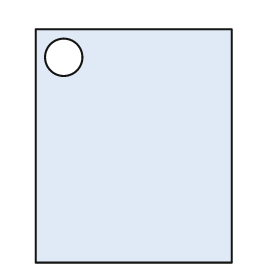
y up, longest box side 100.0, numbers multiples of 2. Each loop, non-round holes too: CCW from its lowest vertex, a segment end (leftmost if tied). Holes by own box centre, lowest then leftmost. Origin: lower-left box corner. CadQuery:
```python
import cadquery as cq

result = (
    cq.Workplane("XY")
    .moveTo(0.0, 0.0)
    .lineTo(84.0, 0.0)
    .lineTo(84.0, 100.0)
    .lineTo(0.0, 100.0)
    .close()
    .moveTo(12.0, 88.0)
    .circle(8.0)
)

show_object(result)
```